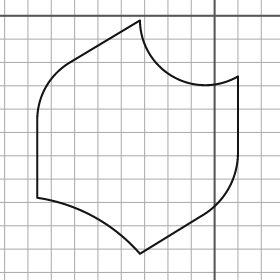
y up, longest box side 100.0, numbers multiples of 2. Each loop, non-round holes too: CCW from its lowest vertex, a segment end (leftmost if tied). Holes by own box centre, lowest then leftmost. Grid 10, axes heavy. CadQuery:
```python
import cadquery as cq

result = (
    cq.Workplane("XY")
    .moveTo(-32.0, -102.0)
    .lineTo(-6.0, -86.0)
    .threePointArc((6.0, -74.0), (10.0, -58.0))
    .lineTo(10.0, -26.0)
    .threePointArc((-18.0, -26.0), (-32.0, -2.0))
    .lineTo(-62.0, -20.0)
    .threePointArc((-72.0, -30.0), (-76.0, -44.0))
    .lineTo(-76.0, -78.0)
    .threePointArc((-52.0, -86.0), (-32.0, -102.0))
    .close()
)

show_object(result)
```